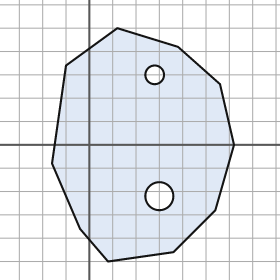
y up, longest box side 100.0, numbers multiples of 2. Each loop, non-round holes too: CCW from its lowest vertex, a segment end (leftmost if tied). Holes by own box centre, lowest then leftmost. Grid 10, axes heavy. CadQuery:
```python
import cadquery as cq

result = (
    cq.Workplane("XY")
    .moveTo(8.0, -50.0)
    .lineTo(36.0, -46.0)
    .lineTo(54.0, -28.0)
    .lineTo(62.0, 0.0)
    .lineTo(56.0, 26.0)
    .lineTo(38.0, 42.0)
    .lineTo(12.0, 50.0)
    .lineTo(-10.0, 34.0)
    .lineTo(-16.0, -8.0)
    .lineTo(-4.0, -36.0)
    .close()
    .moveTo(30.0, -22.0)
    .circle(6.0)
    .moveTo(28.0, 30.0)
    .circle(4.0)
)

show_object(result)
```